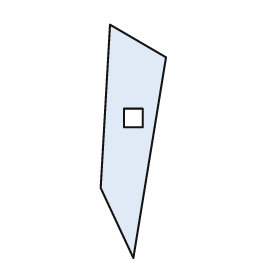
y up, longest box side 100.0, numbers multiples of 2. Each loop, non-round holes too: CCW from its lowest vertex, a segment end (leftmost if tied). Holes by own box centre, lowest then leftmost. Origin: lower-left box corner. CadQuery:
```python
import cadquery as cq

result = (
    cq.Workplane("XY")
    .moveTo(14.0, 0.0)
    .lineTo(28.0, 86.0)
    .lineTo(4.0, 100.0)
    .lineTo(0.0, 30.0)
    .close()
    .moveTo(10.0, 56.0)
    .lineTo(18.0, 56.0)
    .lineTo(18.0, 64.0)
    .lineTo(10.0, 64.0)
    .close()
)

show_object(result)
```